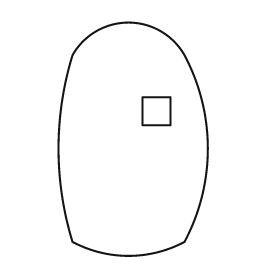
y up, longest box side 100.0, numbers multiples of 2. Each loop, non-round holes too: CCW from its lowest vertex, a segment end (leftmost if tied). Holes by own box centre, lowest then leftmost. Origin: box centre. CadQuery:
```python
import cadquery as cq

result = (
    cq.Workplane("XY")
    .moveTo(-26.0, -44.0)
    .threePointArc((-2.0, -50.0), (22.0, -44.0))
    .threePointArc((32.0, -4.0), (22.0, 36.0))
    .threePointArc((-2.0, 50.0), (-26.0, 36.0))
    .threePointArc((-32.0, -4.0), (-26.0, -44.0))
    .close()
    .moveTo(4.0, 6.0)
    .lineTo(16.0, 6.0)
    .lineTo(16.0, 18.0)
    .lineTo(4.0, 18.0)
    .close()
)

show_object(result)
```